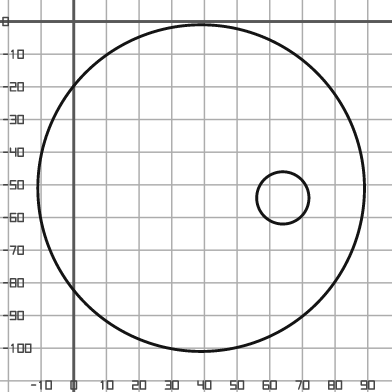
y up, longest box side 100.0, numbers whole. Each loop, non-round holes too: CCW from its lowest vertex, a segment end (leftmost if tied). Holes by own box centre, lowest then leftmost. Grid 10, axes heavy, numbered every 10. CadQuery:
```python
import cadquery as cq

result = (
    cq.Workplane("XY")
    .moveTo(39.0, -51.0)
    .circle(50.0)
    .moveTo(64.0, -54.0)
    .circle(8.0)
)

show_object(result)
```